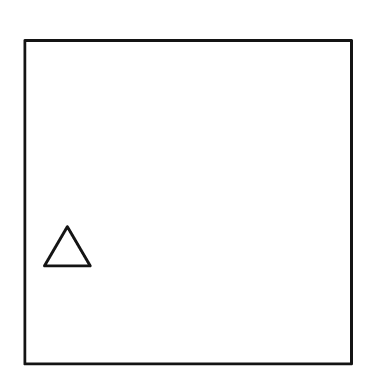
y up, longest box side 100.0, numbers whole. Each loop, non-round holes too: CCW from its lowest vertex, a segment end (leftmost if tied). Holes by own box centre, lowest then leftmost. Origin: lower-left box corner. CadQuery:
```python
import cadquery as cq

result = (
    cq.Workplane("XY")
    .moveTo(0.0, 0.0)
    .lineTo(100.0, 0.0)
    .lineTo(100.0, 99.0)
    .lineTo(0.0, 99.0)
    .close()
    .moveTo(6.0, 30.0)
    .lineTo(20.0, 30.0)
    .lineTo(13.0, 42.0)
    .close()
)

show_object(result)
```